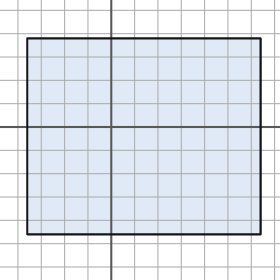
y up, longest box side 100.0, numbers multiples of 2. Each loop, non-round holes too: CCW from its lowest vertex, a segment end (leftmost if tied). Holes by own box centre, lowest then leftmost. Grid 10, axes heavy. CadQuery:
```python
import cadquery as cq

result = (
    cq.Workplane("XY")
    .moveTo(-36.0, -46.0)
    .lineTo(64.0, -46.0)
    .lineTo(64.0, 38.0)
    .lineTo(-36.0, 38.0)
    .close()
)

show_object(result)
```